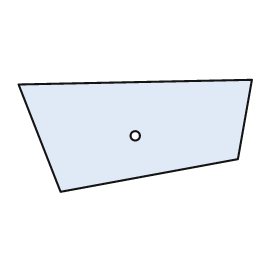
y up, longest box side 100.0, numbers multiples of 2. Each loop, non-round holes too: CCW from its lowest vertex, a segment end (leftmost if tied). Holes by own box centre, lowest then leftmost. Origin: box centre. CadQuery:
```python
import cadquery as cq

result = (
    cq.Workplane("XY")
    .moveTo(-32.0, -24.0)
    .lineTo(44.0, -10.0)
    .lineTo(50.0, 24.0)
    .lineTo(-50.0, 22.0)
    .close()
    .moveTo(0.0, 0.0)
    .circle(2.0)
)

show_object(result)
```